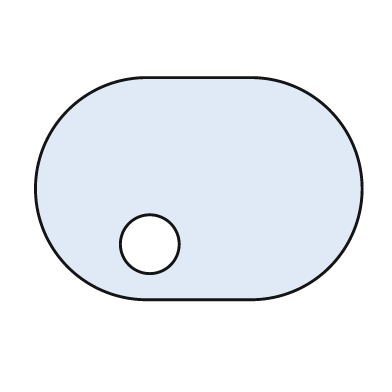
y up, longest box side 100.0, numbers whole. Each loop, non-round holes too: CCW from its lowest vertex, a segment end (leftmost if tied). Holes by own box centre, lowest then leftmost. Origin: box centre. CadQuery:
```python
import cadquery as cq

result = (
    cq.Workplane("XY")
    .moveTo(-16.0, -34.0)
    .lineTo(16.0, -34.0)
    .threePointArc((50.0, 0.0), (16.0, 34.0))
    .lineTo(-16.0, 34.0)
    .threePointArc((-50.0, 0.0), (-16.0, -34.0))
    .close()
    .moveTo(-15.0, -17.0)
    .circle(9.0)
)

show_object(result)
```